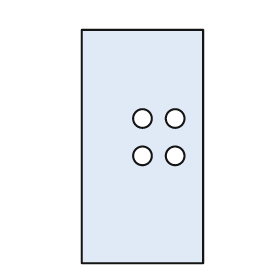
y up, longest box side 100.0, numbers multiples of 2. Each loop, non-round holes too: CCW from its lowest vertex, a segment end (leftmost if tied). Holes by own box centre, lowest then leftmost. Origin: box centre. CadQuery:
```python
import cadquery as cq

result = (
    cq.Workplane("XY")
    .moveTo(-26.0, -50.0)
    .lineTo(26.0, -50.0)
    .lineTo(26.0, 50.0)
    .lineTo(-26.0, 50.0)
    .close()
    .moveTo(0.0, -4.0)
    .circle(4.0)
    .moveTo(14.0, -4.0)
    .circle(4.0)
    .moveTo(0.0, 12.0)
    .circle(4.0)
    .moveTo(14.0, 12.0)
    .circle(4.0)
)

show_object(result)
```